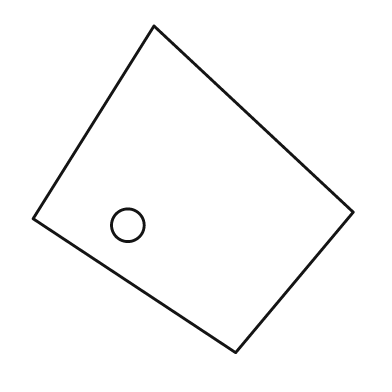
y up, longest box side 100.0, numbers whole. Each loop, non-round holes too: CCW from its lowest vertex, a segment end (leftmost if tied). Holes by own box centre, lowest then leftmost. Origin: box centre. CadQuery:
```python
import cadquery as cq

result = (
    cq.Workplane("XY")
    .moveTo(13.0, -50.0)
    .lineTo(49.0, -7.0)
    .lineTo(-12.0, 50.0)
    .lineTo(-49.0, -9.0)
    .close()
    .moveTo(-20.0, -11.0)
    .circle(5.0)
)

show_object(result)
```